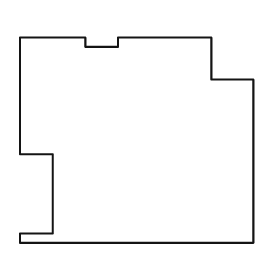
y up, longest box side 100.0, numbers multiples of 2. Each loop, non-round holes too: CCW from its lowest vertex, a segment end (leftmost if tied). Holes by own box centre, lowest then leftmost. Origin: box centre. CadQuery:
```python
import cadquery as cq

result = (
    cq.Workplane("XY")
    .moveTo(-50.0, -44.0)
    .lineTo(50.0, -44.0)
    .lineTo(50.0, 26.0)
    .lineTo(32.0, 26.0)
    .lineTo(32.0, 44.0)
    .lineTo(-8.0, 44.0)
    .lineTo(-8.0, 40.0)
    .lineTo(-22.0, 40.0)
    .lineTo(-22.0, 44.0)
    .lineTo(-50.0, 44.0)
    .lineTo(-50.0, -6.0)
    .lineTo(-36.0, -6.0)
    .lineTo(-36.0, -40.0)
    .lineTo(-50.0, -40.0)
    .close()
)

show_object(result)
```